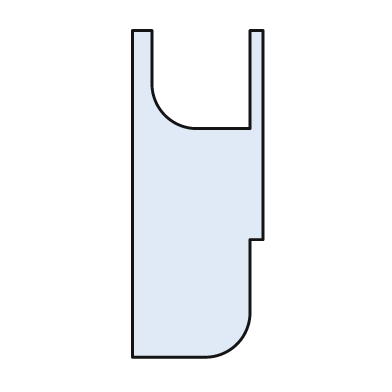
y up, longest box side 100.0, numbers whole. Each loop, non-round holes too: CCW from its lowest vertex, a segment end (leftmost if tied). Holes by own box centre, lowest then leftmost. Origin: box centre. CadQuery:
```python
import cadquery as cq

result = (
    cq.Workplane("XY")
    .moveTo(-20.0, -50.0)
    .lineTo(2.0, -50.0)
    .threePointArc((12.0, -46.0), (16.0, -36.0))
    .lineTo(16.0, -14.0)
    .lineTo(20.0, -14.0)
    .lineTo(20.0, 50.0)
    .lineTo(16.0, 50.0)
    .lineTo(16.0, 20.0)
    .lineTo(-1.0, 20.0)
    .threePointArc((-10.0, 24.0), (-14.0, 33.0))
    .lineTo(-14.0, 50.0)
    .lineTo(-20.0, 50.0)
    .close()
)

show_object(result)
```